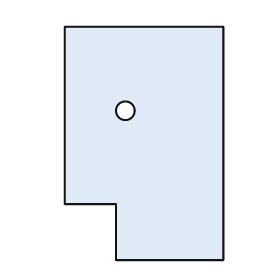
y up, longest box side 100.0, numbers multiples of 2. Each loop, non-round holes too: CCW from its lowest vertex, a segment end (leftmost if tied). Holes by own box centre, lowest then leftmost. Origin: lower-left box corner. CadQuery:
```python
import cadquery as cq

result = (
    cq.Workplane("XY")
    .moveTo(22.0, 0.0)
    .lineTo(68.0, 0.0)
    .lineTo(68.0, 100.0)
    .lineTo(0.0, 100.0)
    .lineTo(0.0, 24.0)
    .lineTo(22.0, 24.0)
    .close()
    .moveTo(26.0, 64.0)
    .circle(4.0)
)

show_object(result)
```